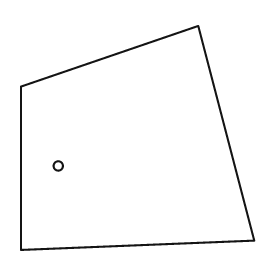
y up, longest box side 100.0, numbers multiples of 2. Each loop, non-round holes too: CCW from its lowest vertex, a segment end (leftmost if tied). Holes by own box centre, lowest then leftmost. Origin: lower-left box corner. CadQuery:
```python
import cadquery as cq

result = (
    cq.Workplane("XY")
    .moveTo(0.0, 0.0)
    .lineTo(100.0, 4.0)
    .lineTo(76.0, 96.0)
    .lineTo(0.0, 70.0)
    .close()
    .moveTo(16.0, 36.0)
    .circle(2.0)
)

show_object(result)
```